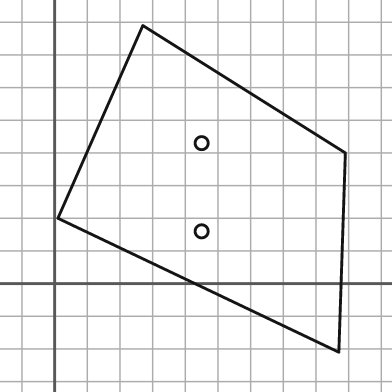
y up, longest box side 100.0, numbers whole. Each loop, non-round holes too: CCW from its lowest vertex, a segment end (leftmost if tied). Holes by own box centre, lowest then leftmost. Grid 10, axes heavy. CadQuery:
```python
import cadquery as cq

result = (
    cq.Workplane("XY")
    .moveTo(87.0, -21.0)
    .lineTo(89.0, 40.0)
    .lineTo(27.0, 79.0)
    .lineTo(1.0, 20.0)
    .close()
    .moveTo(45.0, 16.0)
    .circle(2.0)
    .moveTo(45.0, 43.0)
    .circle(2.0)
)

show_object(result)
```